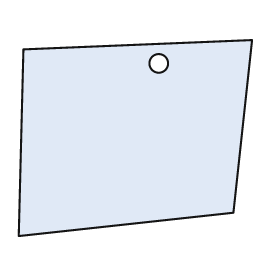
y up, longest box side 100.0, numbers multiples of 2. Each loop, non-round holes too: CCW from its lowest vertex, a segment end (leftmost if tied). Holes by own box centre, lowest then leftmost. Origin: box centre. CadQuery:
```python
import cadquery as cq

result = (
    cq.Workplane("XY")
    .moveTo(-50.0, -42.0)
    .lineTo(42.0, -32.0)
    .lineTo(50.0, 42.0)
    .lineTo(-48.0, 38.0)
    .close()
    .moveTo(10.0, 32.0)
    .circle(4.0)
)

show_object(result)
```